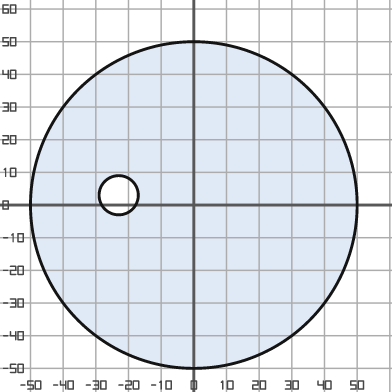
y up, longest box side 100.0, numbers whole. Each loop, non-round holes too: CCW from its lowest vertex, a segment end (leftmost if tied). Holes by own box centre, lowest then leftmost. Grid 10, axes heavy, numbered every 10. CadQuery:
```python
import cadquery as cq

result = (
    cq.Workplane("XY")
    .moveTo(0.0, 0.0)
    .circle(50.0)
    .moveTo(-23.0, 3.0)
    .circle(6.0)
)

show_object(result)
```